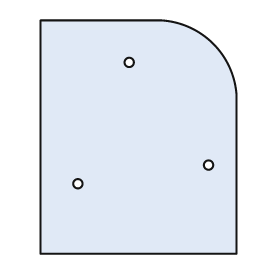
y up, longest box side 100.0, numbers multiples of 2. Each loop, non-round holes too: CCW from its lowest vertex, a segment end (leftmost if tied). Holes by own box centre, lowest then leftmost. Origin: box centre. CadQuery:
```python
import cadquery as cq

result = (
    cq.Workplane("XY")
    .moveTo(-42.0, -50.0)
    .lineTo(42.0, -50.0)
    .lineTo(42.0, 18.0)
    .threePointArc((32.0, 40.0), (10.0, 50.0))
    .lineTo(-42.0, 50.0)
    .close()
    .moveTo(-26.0, -20.0)
    .circle(2.0)
    .moveTo(30.0, -12.0)
    .circle(2.0)
    .moveTo(-4.0, 32.0)
    .circle(2.0)
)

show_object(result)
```